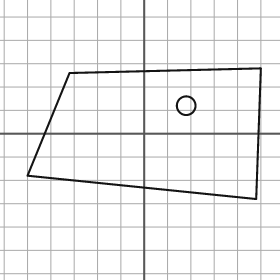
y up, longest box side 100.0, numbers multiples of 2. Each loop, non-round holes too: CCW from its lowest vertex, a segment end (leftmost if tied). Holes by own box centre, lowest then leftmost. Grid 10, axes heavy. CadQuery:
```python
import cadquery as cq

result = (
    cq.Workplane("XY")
    .moveTo(48.0, -28.0)
    .lineTo(50.0, 28.0)
    .lineTo(-32.0, 26.0)
    .lineTo(-50.0, -18.0)
    .close()
    .moveTo(18.0, 12.0)
    .circle(4.0)
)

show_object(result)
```